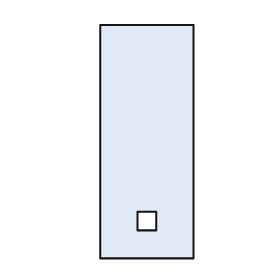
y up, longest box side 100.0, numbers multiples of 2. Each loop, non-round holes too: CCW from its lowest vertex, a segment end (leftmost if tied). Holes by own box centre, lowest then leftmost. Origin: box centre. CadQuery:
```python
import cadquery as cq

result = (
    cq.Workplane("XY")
    .moveTo(-20.0, -50.0)
    .lineTo(20.0, -50.0)
    .lineTo(20.0, 50.0)
    .lineTo(-20.0, 50.0)
    .close()
    .moveTo(-4.0, -38.0)
    .lineTo(4.0, -38.0)
    .lineTo(4.0, -30.0)
    .lineTo(-4.0, -30.0)
    .close()
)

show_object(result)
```